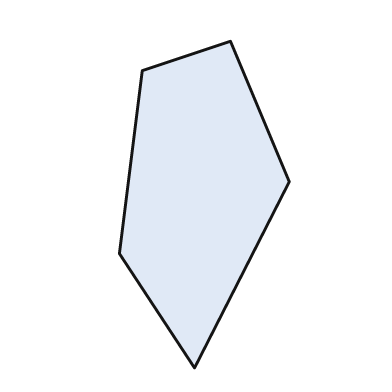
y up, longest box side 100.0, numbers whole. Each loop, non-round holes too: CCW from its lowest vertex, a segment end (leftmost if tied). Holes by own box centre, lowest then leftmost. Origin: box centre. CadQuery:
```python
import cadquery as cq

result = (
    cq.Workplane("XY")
    .moveTo(-3.0, -50.0)
    .lineTo(26.0, 7.0)
    .lineTo(8.0, 50.0)
    .lineTo(-19.0, 41.0)
    .lineTo(-26.0, -15.0)
    .close()
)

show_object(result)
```